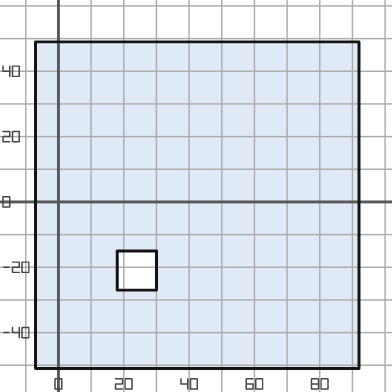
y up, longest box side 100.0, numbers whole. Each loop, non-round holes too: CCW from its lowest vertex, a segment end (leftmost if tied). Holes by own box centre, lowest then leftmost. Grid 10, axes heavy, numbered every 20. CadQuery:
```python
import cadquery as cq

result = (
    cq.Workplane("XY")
    .moveTo(-7.0, -51.0)
    .lineTo(92.0, -51.0)
    .lineTo(92.0, 49.0)
    .lineTo(-7.0, 49.0)
    .close()
    .moveTo(18.0, -27.0)
    .lineTo(30.0, -27.0)
    .lineTo(30.0, -15.0)
    .lineTo(18.0, -15.0)
    .close()
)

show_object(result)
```